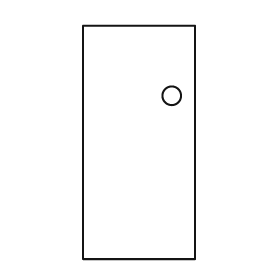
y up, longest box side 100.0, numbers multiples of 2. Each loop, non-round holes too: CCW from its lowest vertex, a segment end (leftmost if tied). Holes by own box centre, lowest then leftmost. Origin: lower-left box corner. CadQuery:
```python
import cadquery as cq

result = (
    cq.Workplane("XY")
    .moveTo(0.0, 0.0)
    .lineTo(48.0, 0.0)
    .lineTo(48.0, 100.0)
    .lineTo(0.0, 100.0)
    .close()
    .moveTo(38.0, 70.0)
    .circle(4.0)
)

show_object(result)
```